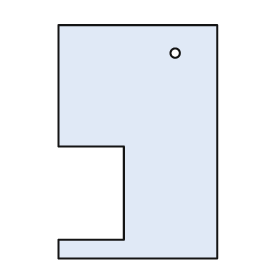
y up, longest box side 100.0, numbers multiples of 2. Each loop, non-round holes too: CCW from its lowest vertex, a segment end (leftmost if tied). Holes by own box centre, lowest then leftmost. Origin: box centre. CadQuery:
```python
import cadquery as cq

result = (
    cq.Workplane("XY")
    .moveTo(-34.0, -50.0)
    .lineTo(34.0, -50.0)
    .lineTo(34.0, 50.0)
    .lineTo(-34.0, 50.0)
    .lineTo(-34.0, -2.0)
    .lineTo(-6.0, -2.0)
    .lineTo(-6.0, -42.0)
    .lineTo(-34.0, -42.0)
    .close()
    .moveTo(16.0, 38.0)
    .circle(2.0)
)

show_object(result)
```